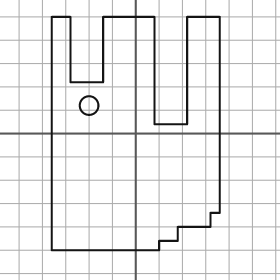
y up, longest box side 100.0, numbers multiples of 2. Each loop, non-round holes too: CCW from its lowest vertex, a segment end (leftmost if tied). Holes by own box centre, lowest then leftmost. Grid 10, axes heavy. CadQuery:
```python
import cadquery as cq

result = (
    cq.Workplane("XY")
    .moveTo(-36.0, -50.0)
    .lineTo(10.0, -50.0)
    .lineTo(10.0, -46.0)
    .lineTo(18.0, -46.0)
    .lineTo(18.0, -40.0)
    .lineTo(32.0, -40.0)
    .lineTo(32.0, -34.0)
    .lineTo(36.0, -34.0)
    .lineTo(36.0, 50.0)
    .lineTo(22.0, 50.0)
    .lineTo(22.0, 4.0)
    .lineTo(8.0, 4.0)
    .lineTo(8.0, 50.0)
    .lineTo(-14.0, 50.0)
    .lineTo(-14.0, 22.0)
    .lineTo(-28.0, 22.0)
    .lineTo(-28.0, 50.0)
    .lineTo(-36.0, 50.0)
    .close()
    .moveTo(-20.0, 12.0)
    .circle(4.0)
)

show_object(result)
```